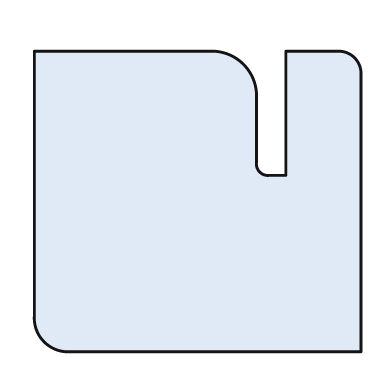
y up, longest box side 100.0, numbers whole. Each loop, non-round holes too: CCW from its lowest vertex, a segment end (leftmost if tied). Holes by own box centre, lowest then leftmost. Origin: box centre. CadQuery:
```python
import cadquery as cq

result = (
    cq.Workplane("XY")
    .moveTo(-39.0, -46.0)
    .lineTo(50.0, -46.0)
    .lineTo(50.0, 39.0)
    .threePointArc((48.0, 44.0), (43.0, 46.0))
    .lineTo(27.0, 46.0)
    .lineTo(27.0, 8.0)
    .lineTo(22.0, 8.0)
    .threePointArc((19.0, 9.0), (18.0, 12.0))
    .lineTo(18.0, 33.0)
    .threePointArc((14.0, 42.0), (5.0, 46.0))
    .lineTo(-50.0, 46.0)
    .lineTo(-50.0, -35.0)
    .threePointArc((-47.0, -43.0), (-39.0, -46.0))
    .close()
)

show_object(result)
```